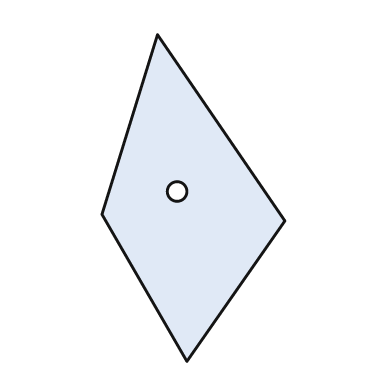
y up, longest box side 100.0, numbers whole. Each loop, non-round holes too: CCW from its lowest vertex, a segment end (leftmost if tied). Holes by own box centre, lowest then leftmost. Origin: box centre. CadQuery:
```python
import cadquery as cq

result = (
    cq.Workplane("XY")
    .moveTo(-2.0, -50.0)
    .lineTo(28.0, -7.0)
    .lineTo(-11.0, 50.0)
    .lineTo(-28.0, -5.0)
    .close()
    .moveTo(-5.0, 2.0)
    .circle(3.0)
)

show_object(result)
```